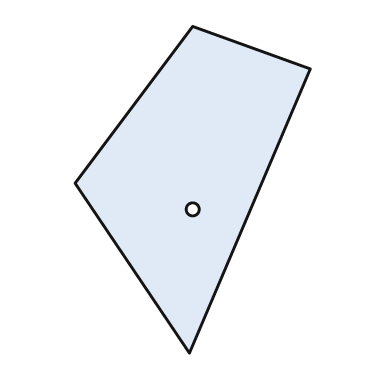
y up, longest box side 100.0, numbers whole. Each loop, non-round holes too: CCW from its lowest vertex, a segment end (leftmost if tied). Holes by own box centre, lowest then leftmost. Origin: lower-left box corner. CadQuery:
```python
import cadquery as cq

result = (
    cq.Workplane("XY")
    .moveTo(35.0, 0.0)
    .lineTo(72.0, 87.0)
    .lineTo(36.0, 100.0)
    .lineTo(0.0, 52.0)
    .close()
    .moveTo(36.0, 44.0)
    .circle(2.0)
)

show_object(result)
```